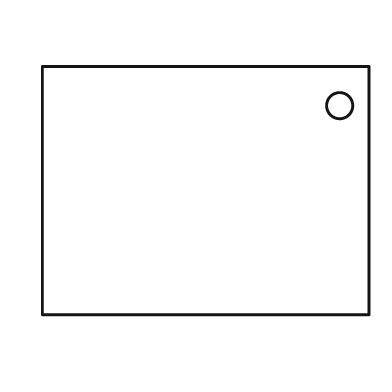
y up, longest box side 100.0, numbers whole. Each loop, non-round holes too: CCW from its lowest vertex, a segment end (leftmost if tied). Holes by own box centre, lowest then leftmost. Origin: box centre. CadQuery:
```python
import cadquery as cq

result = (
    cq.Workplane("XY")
    .moveTo(-50.0, -38.0)
    .lineTo(50.0, -38.0)
    .lineTo(50.0, 38.0)
    .lineTo(-50.0, 38.0)
    .close()
    .moveTo(41.0, 26.0)
    .circle(4.0)
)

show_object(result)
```